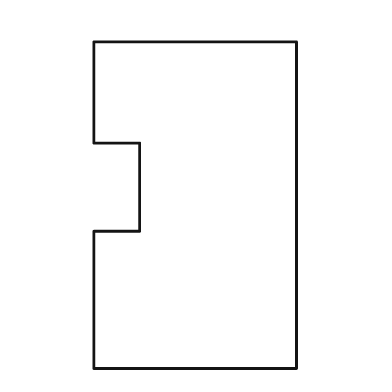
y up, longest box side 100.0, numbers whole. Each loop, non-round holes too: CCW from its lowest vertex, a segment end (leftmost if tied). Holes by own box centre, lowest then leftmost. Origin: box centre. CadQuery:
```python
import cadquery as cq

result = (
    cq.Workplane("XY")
    .moveTo(-31.0, -50.0)
    .lineTo(31.0, -50.0)
    .lineTo(31.0, 50.0)
    .lineTo(-31.0, 50.0)
    .lineTo(-31.0, 19.0)
    .lineTo(-17.0, 19.0)
    .lineTo(-17.0, -8.0)
    .lineTo(-31.0, -8.0)
    .close()
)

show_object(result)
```